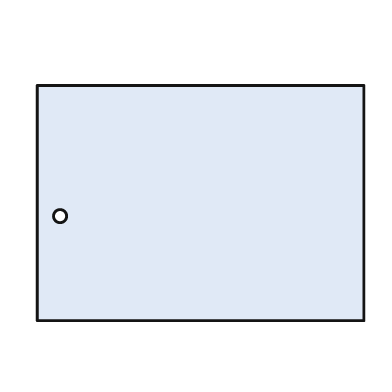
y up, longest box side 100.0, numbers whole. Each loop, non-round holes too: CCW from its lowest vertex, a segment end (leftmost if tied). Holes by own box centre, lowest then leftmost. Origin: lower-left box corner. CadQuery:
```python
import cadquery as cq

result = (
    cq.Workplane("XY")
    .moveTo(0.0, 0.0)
    .lineTo(100.0, 0.0)
    .lineTo(100.0, 72.0)
    .lineTo(0.0, 72.0)
    .close()
    .moveTo(7.0, 32.0)
    .circle(2.0)
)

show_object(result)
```